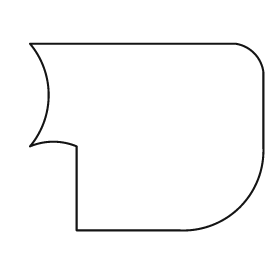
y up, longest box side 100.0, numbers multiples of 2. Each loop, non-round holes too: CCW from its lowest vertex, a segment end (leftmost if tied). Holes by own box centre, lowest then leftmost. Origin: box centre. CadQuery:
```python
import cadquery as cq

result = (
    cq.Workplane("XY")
    .moveTo(-30.0, -40.0)
    .lineTo(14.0, -40.0)
    .threePointArc((40.0, -30.0), (50.0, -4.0))
    .lineTo(50.0, 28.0)
    .threePointArc((46.0, 36.0), (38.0, 40.0))
    .lineTo(-50.0, 40.0)
    .threePointArc((-42.0, 18.0), (-50.0, -4.0))
    .threePointArc((-40.0, -2.0), (-30.0, -4.0))
    .close()
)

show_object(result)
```